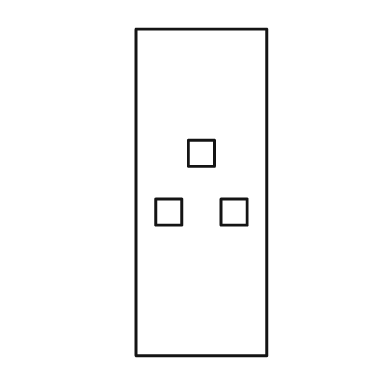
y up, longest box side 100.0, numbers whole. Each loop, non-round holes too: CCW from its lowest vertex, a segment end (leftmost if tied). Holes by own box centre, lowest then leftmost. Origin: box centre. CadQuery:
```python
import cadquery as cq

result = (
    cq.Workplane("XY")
    .moveTo(-20.0, -50.0)
    .lineTo(20.0, -50.0)
    .lineTo(20.0, 50.0)
    .lineTo(-20.0, 50.0)
    .close()
    .moveTo(-14.0, -10.0)
    .lineTo(-6.0, -10.0)
    .lineTo(-6.0, -2.0)
    .lineTo(-14.0, -2.0)
    .close()
    .moveTo(6.0, -10.0)
    .lineTo(14.0, -10.0)
    .lineTo(14.0, -2.0)
    .lineTo(6.0, -2.0)
    .close()
    .moveTo(-4.0, 8.0)
    .lineTo(4.0, 8.0)
    .lineTo(4.0, 16.0)
    .lineTo(-4.0, 16.0)
    .close()
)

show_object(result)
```